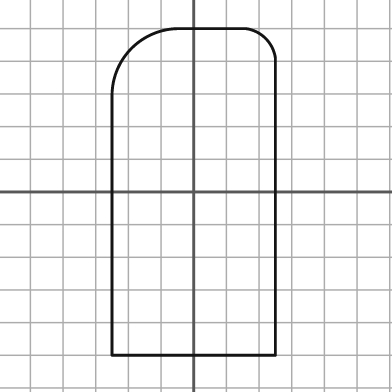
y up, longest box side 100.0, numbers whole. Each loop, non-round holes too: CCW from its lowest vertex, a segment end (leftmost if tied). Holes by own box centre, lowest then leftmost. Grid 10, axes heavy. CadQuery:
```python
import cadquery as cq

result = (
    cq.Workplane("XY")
    .moveTo(-25.0, -50.0)
    .lineTo(25.0, -50.0)
    .lineTo(25.0, 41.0)
    .threePointArc((22.0, 47.0), (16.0, 50.0))
    .lineTo(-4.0, 50.0)
    .threePointArc((-19.0, 44.0), (-25.0, 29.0))
    .close()
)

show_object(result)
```